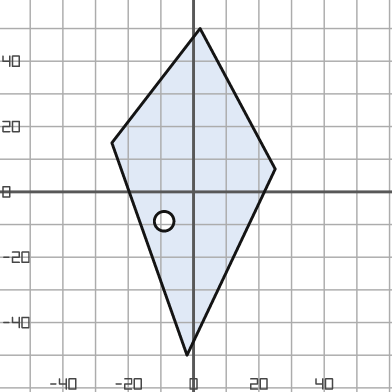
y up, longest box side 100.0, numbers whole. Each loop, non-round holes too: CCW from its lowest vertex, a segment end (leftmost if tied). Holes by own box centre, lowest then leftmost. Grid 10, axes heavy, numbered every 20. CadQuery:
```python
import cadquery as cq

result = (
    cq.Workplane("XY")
    .moveTo(-2.0, -50.0)
    .lineTo(25.0, 7.0)
    .lineTo(2.0, 50.0)
    .lineTo(-25.0, 15.0)
    .close()
    .moveTo(-9.0, -9.0)
    .circle(3.0)
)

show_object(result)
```